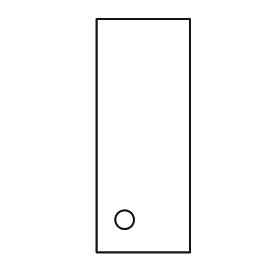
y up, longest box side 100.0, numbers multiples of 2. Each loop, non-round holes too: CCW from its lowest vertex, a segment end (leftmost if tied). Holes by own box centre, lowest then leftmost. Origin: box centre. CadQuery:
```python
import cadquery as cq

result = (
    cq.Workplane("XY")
    .moveTo(-20.0, -50.0)
    .lineTo(20.0, -50.0)
    .lineTo(20.0, 50.0)
    .lineTo(-20.0, 50.0)
    .close()
    .moveTo(-8.0, -36.0)
    .circle(4.0)
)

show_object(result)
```